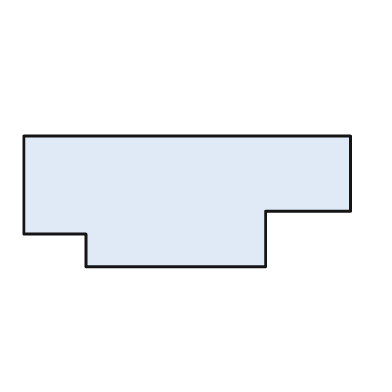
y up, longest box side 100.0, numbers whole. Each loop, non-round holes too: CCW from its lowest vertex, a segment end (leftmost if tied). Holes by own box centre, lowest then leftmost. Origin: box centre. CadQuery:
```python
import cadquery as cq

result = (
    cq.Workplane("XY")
    .moveTo(-31.0, -20.0)
    .lineTo(24.0, -20.0)
    .lineTo(24.0, -3.0)
    .lineTo(50.0, -3.0)
    .lineTo(50.0, 20.0)
    .lineTo(-50.0, 20.0)
    .lineTo(-50.0, -10.0)
    .lineTo(-31.0, -10.0)
    .close()
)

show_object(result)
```